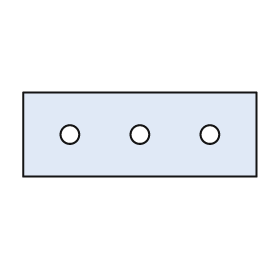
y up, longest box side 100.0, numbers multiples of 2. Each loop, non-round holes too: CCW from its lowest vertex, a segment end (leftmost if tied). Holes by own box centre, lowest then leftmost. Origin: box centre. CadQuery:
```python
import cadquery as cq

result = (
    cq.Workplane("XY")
    .moveTo(-50.0, -18.0)
    .lineTo(50.0, -18.0)
    .lineTo(50.0, 18.0)
    .lineTo(-50.0, 18.0)
    .close()
    .moveTo(-30.0, 0.0)
    .circle(4.0)
    .moveTo(0.0, 0.0)
    .circle(4.0)
    .moveTo(30.0, 0.0)
    .circle(4.0)
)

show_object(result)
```